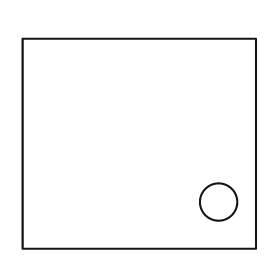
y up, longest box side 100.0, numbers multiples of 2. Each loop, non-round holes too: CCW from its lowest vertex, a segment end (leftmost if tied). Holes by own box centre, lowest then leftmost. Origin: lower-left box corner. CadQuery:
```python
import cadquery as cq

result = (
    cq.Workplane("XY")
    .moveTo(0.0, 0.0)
    .lineTo(100.0, 0.0)
    .lineTo(100.0, 90.0)
    .lineTo(0.0, 90.0)
    .close()
    .moveTo(84.0, 20.0)
    .circle(8.0)
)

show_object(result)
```